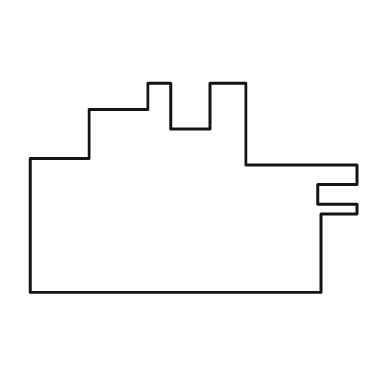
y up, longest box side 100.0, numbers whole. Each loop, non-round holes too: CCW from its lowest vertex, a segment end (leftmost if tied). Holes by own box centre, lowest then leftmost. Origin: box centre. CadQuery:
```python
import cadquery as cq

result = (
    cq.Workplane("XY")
    .moveTo(-50.0, -32.0)
    .lineTo(39.0, -32.0)
    .lineTo(39.0, -8.0)
    .lineTo(50.0, -8.0)
    .lineTo(50.0, -5.0)
    .lineTo(38.0, -5.0)
    .lineTo(38.0, 1.0)
    .lineTo(50.0, 1.0)
    .lineTo(50.0, 7.0)
    .lineTo(16.0, 7.0)
    .lineTo(16.0, 32.0)
    .lineTo(5.0, 32.0)
    .lineTo(5.0, 18.0)
    .lineTo(-7.0, 18.0)
    .lineTo(-7.0, 32.0)
    .lineTo(-14.0, 32.0)
    .lineTo(-14.0, 24.0)
    .lineTo(-32.0, 24.0)
    .lineTo(-32.0, 9.0)
    .lineTo(-50.0, 9.0)
    .close()
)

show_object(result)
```